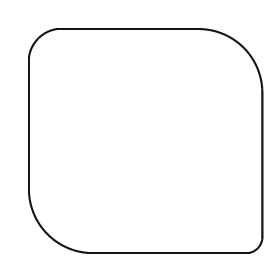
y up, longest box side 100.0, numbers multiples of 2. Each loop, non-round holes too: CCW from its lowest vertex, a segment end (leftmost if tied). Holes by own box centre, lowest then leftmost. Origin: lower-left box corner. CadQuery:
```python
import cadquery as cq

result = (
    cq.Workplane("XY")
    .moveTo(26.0, 0.0)
    .lineTo(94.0, 0.0)
    .threePointArc((98.0, 2.0), (100.0, 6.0))
    .lineTo(100.0, 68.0)
    .threePointArc((92.0, 88.0), (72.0, 96.0))
    .lineTo(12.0, 96.0)
    .threePointArc((4.0, 92.0), (0.0, 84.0))
    .lineTo(0.0, 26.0)
    .threePointArc((8.0, 8.0), (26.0, 0.0))
    .close()
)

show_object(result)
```